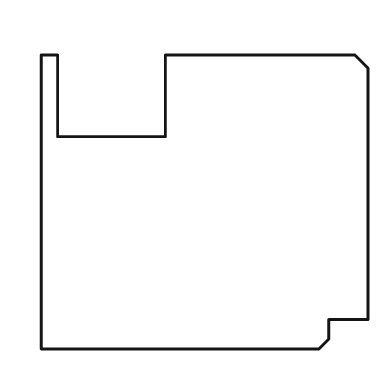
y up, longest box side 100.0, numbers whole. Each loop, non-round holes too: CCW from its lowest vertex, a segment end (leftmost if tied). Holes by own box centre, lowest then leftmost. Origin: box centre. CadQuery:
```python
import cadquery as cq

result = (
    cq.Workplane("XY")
    .moveTo(-50.0, -45.0)
    .lineTo(35.0, -45.0)
    .lineTo(38.0, -42.0)
    .lineTo(38.0, -36.0)
    .lineTo(50.0, -36.0)
    .lineTo(50.0, 41.0)
    .lineTo(46.0, 45.0)
    .lineTo(-12.0, 45.0)
    .lineTo(-12.0, 20.0)
    .lineTo(-45.0, 20.0)
    .lineTo(-45.0, 45.0)
    .lineTo(-50.0, 45.0)
    .close()
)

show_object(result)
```